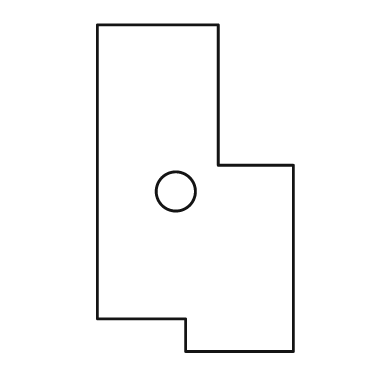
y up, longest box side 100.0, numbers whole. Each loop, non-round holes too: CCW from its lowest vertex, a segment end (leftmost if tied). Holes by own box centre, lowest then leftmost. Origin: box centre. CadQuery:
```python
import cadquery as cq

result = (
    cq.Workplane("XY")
    .moveTo(-3.0, -50.0)
    .lineTo(30.0, -50.0)
    .lineTo(30.0, 7.0)
    .lineTo(7.0, 7.0)
    .lineTo(7.0, 50.0)
    .lineTo(-30.0, 50.0)
    .lineTo(-30.0, -40.0)
    .lineTo(-3.0, -40.0)
    .close()
    .moveTo(-6.0, -1.0)
    .circle(6.0)
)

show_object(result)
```